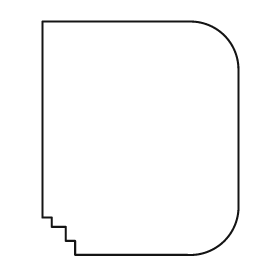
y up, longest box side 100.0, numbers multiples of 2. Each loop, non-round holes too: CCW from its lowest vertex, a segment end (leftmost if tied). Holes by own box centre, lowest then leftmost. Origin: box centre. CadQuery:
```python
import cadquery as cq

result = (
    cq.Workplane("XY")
    .moveTo(-28.0, -50.0)
    .lineTo(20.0, -50.0)
    .threePointArc((36.0, -44.0), (42.0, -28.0))
    .lineTo(42.0, 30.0)
    .threePointArc((36.0, 44.0), (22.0, 50.0))
    .lineTo(-42.0, 50.0)
    .lineTo(-42.0, -34.0)
    .lineTo(-38.0, -34.0)
    .lineTo(-38.0, -38.0)
    .lineTo(-32.0, -38.0)
    .lineTo(-32.0, -44.0)
    .lineTo(-28.0, -44.0)
    .close()
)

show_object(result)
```